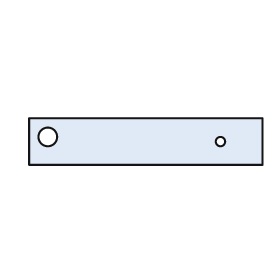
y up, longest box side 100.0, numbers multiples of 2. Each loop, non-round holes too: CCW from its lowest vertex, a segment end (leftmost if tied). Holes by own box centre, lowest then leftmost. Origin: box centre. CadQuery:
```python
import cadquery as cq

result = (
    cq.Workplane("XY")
    .moveTo(-50.0, -10.0)
    .lineTo(50.0, -10.0)
    .lineTo(50.0, 10.0)
    .lineTo(-50.0, 10.0)
    .close()
    .moveTo(32.0, 0.0)
    .circle(2.0)
    .moveTo(-42.0, 2.0)
    .circle(4.0)
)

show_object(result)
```